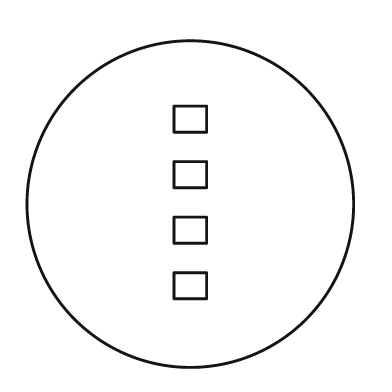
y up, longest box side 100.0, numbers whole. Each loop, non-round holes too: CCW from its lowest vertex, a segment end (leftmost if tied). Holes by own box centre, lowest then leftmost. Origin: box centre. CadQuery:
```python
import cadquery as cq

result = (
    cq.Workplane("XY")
    .moveTo(0.0, 0.0)
    .circle(50.0)
    .moveTo(-5.0, -29.0)
    .lineTo(5.0, -29.0)
    .lineTo(5.0, -21.0)
    .lineTo(-5.0, -21.0)
    .close()
    .moveTo(-5.0, -12.0)
    .lineTo(5.0, -12.0)
    .lineTo(5.0, -4.0)
    .lineTo(-5.0, -4.0)
    .close()
    .moveTo(-5.0, 5.0)
    .lineTo(5.0, 5.0)
    .lineTo(5.0, 13.0)
    .lineTo(-5.0, 13.0)
    .close()
    .moveTo(-5.0, 22.0)
    .lineTo(5.0, 22.0)
    .lineTo(5.0, 30.0)
    .lineTo(-5.0, 30.0)
    .close()
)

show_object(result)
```